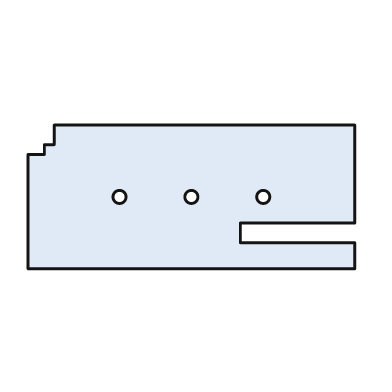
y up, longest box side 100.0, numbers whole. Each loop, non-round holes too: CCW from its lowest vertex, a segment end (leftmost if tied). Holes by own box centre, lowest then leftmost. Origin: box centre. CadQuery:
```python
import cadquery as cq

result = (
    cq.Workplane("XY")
    .moveTo(-50.0, -22.0)
    .lineTo(50.0, -22.0)
    .lineTo(50.0, -14.0)
    .lineTo(15.0, -14.0)
    .lineTo(15.0, -8.0)
    .lineTo(50.0, -8.0)
    .lineTo(50.0, 22.0)
    .lineTo(-42.0, 22.0)
    .lineTo(-42.0, 16.0)
    .lineTo(-45.0, 16.0)
    .lineTo(-45.0, 13.0)
    .lineTo(-50.0, 13.0)
    .close()
    .moveTo(-22.0, 0.0)
    .circle(2.0)
    .moveTo(0.0, 0.0)
    .circle(2.0)
    .moveTo(22.0, 0.0)
    .circle(2.0)
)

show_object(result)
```